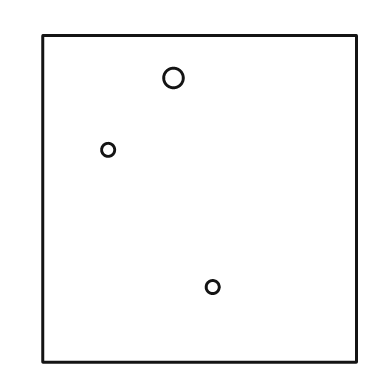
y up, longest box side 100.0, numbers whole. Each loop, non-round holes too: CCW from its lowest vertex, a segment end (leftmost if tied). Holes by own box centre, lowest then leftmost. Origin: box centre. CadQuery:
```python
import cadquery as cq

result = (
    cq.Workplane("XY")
    .moveTo(-48.0, -50.0)
    .lineTo(48.0, -50.0)
    .lineTo(48.0, 50.0)
    .lineTo(-48.0, 50.0)
    .close()
    .moveTo(4.0, -27.0)
    .circle(2.0)
    .moveTo(-28.0, 15.0)
    .circle(2.0)
    .moveTo(-8.0, 37.0)
    .circle(3.0)
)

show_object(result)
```